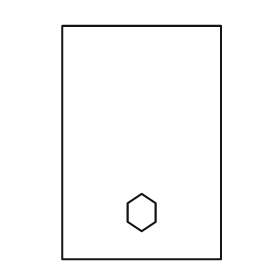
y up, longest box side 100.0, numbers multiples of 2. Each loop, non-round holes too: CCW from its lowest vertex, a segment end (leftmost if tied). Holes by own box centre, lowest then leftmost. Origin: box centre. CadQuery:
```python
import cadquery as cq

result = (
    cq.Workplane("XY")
    .moveTo(-34.0, -50.0)
    .lineTo(34.0, -50.0)
    .lineTo(34.0, 50.0)
    .lineTo(-34.0, 50.0)
    .close()
    .moveTo(0.0, -38.0)
    .lineTo(6.0, -34.0)
    .lineTo(6.0, -26.0)
    .lineTo(0.0, -22.0)
    .lineTo(-6.0, -26.0)
    .lineTo(-6.0, -34.0)
    .close()
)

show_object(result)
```